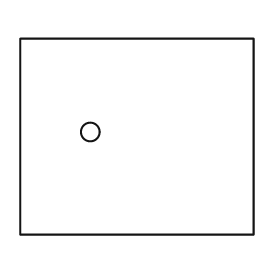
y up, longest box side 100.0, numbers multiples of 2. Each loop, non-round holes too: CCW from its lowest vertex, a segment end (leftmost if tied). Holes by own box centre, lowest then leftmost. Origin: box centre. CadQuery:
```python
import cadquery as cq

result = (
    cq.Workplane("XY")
    .moveTo(-50.0, -42.0)
    .lineTo(50.0, -42.0)
    .lineTo(50.0, 42.0)
    .lineTo(-50.0, 42.0)
    .close()
    .moveTo(-20.0, 2.0)
    .circle(4.0)
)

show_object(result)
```